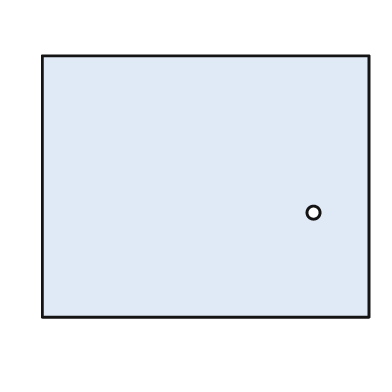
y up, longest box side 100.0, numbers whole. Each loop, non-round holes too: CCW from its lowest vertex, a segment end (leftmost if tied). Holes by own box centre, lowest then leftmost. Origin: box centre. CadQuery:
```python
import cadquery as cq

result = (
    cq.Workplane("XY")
    .moveTo(-50.0, -40.0)
    .lineTo(50.0, -40.0)
    .lineTo(50.0, 40.0)
    .lineTo(-50.0, 40.0)
    .close()
    .moveTo(33.0, -8.0)
    .circle(2.0)
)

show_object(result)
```